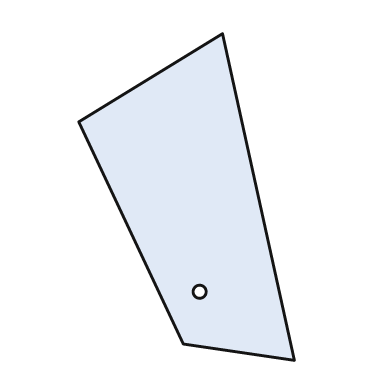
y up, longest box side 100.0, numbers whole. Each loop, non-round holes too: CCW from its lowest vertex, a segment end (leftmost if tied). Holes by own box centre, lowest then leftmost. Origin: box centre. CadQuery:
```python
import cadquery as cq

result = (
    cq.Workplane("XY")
    .moveTo(33.0, -50.0)
    .lineTo(11.0, 50.0)
    .lineTo(-33.0, 23.0)
    .lineTo(-1.0, -45.0)
    .close()
    .moveTo(4.0, -29.0)
    .circle(2.0)
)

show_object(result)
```